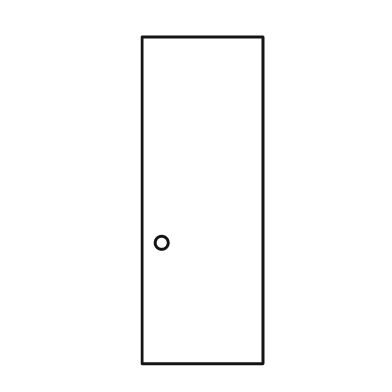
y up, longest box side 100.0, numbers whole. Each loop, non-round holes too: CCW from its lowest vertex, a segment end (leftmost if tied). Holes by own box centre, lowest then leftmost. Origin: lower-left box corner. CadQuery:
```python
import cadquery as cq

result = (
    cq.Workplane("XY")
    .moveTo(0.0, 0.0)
    .lineTo(37.0, 0.0)
    .lineTo(37.0, 100.0)
    .lineTo(0.0, 100.0)
    .close()
    .moveTo(6.0, 37.0)
    .circle(2.0)
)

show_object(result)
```